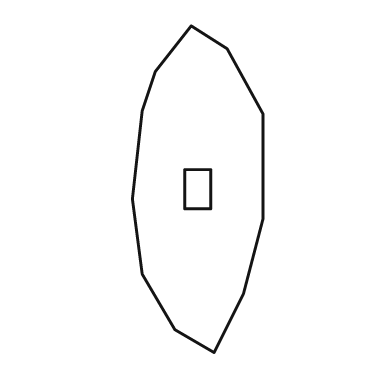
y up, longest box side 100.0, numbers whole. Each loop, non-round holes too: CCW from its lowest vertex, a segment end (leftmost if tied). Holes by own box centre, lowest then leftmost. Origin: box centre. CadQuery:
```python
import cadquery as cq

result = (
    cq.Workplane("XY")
    .moveTo(5.0, -50.0)
    .lineTo(14.0, -32.0)
    .lineTo(20.0, -9.0)
    .lineTo(20.0, 23.0)
    .lineTo(9.0, 43.0)
    .lineTo(-2.0, 50.0)
    .lineTo(-13.0, 36.0)
    .lineTo(-17.0, 24.0)
    .lineTo(-20.0, -3.0)
    .lineTo(-17.0, -26.0)
    .lineTo(-7.0, -43.0)
    .close()
    .moveTo(-4.0, -6.0)
    .lineTo(4.0, -6.0)
    .lineTo(4.0, 6.0)
    .lineTo(-4.0, 6.0)
    .close()
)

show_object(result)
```